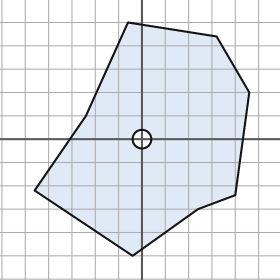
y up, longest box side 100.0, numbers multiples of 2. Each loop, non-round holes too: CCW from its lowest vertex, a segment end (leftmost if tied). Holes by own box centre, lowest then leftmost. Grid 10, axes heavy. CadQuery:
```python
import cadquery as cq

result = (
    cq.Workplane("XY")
    .moveTo(-4.0, -50.0)
    .lineTo(24.0, -30.0)
    .lineTo(40.0, -24.0)
    .lineTo(46.0, 20.0)
    .lineTo(32.0, 44.0)
    .lineTo(-6.0, 50.0)
    .lineTo(-24.0, 10.0)
    .lineTo(-46.0, -22.0)
    .close()
    .moveTo(0.0, 0.0)
    .circle(4.0)
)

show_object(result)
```